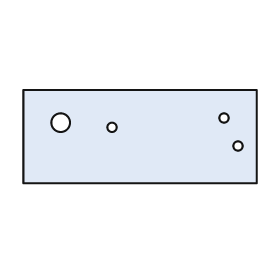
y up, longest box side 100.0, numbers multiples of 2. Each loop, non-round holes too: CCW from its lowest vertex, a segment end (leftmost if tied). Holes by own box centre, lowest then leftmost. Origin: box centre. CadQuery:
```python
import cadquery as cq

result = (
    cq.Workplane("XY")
    .moveTo(-50.0, -20.0)
    .lineTo(50.0, -20.0)
    .lineTo(50.0, 20.0)
    .lineTo(-50.0, 20.0)
    .close()
    .moveTo(42.0, -4.0)
    .circle(2.0)
    .moveTo(-12.0, 4.0)
    .circle(2.0)
    .moveTo(-34.0, 6.0)
    .circle(4.0)
    .moveTo(36.0, 8.0)
    .circle(2.0)
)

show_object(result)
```